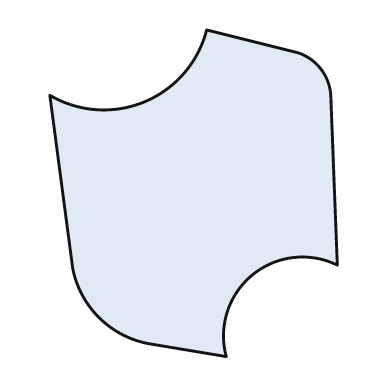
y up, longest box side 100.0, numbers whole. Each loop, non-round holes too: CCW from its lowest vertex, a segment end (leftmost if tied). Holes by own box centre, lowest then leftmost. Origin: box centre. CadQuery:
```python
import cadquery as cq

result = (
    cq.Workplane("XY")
    .moveTo(10.0, -50.0)
    .threePointArc((18.0, -25.0), (44.0, -22.0))
    .lineTo(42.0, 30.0)
    .threePointArc((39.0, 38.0), (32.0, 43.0))
    .lineTo(4.0, 50.0)
    .threePointArc((-15.0, 28.0), (-44.0, 30.0))
    .lineTo(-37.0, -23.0)
    .threePointArc((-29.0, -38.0), (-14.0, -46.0))
    .close()
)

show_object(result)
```